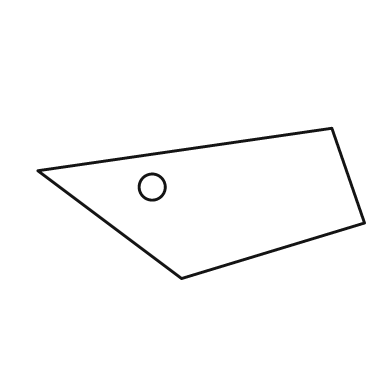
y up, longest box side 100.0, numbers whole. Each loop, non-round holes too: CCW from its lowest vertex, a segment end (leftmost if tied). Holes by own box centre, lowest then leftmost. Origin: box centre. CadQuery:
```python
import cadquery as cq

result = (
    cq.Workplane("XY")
    .moveTo(-6.0, -23.0)
    .lineTo(50.0, -6.0)
    .lineTo(40.0, 23.0)
    .lineTo(-50.0, 10.0)
    .close()
    .moveTo(-15.0, 5.0)
    .circle(4.0)
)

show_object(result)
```